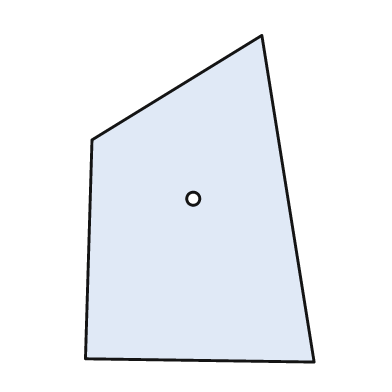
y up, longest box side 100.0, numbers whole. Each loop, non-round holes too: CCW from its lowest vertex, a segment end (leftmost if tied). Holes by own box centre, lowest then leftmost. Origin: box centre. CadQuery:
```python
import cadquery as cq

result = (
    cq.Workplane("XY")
    .moveTo(35.0, -50.0)
    .lineTo(19.0, 50.0)
    .lineTo(-33.0, 18.0)
    .lineTo(-35.0, -49.0)
    .close()
    .moveTo(-2.0, 0.0)
    .circle(2.0)
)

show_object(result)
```